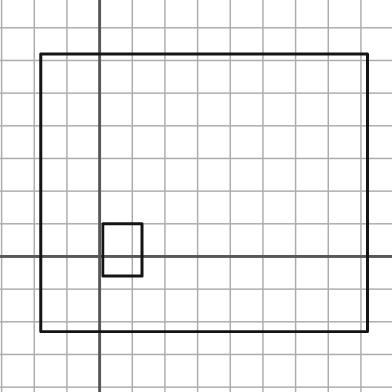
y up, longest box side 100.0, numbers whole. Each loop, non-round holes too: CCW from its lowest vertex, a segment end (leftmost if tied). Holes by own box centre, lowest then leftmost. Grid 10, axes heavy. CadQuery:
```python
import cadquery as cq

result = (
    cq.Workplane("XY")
    .moveTo(-18.0, -23.0)
    .lineTo(82.0, -23.0)
    .lineTo(82.0, 62.0)
    .lineTo(-18.0, 62.0)
    .close()
    .moveTo(1.0, -6.0)
    .lineTo(13.0, -6.0)
    .lineTo(13.0, 10.0)
    .lineTo(1.0, 10.0)
    .close()
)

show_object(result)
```